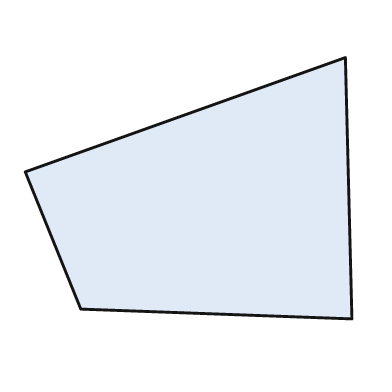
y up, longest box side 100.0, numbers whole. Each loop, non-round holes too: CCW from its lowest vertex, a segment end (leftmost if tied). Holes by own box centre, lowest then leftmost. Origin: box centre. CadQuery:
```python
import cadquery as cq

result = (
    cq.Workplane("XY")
    .moveTo(50.0, -40.0)
    .lineTo(48.0, 40.0)
    .lineTo(-50.0, 5.0)
    .lineTo(-33.0, -37.0)
    .close()
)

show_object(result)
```